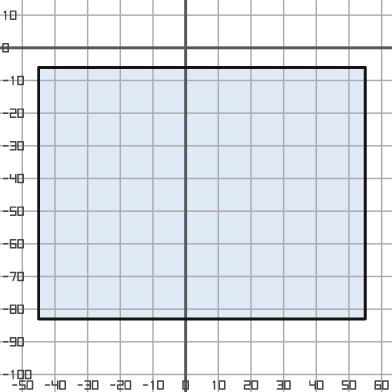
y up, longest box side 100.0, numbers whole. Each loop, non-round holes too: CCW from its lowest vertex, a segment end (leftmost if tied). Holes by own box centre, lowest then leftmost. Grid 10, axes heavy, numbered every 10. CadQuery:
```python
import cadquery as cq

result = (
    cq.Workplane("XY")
    .moveTo(-45.0, -83.0)
    .lineTo(55.0, -83.0)
    .lineTo(55.0, -6.0)
    .lineTo(-45.0, -6.0)
    .close()
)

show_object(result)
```